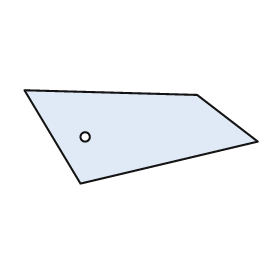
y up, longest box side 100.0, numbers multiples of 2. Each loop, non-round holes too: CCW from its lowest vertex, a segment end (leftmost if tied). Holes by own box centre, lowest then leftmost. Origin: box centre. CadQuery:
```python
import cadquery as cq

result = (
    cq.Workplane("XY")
    .moveTo(-26.0, -20.0)
    .lineTo(50.0, -2.0)
    .lineTo(24.0, 18.0)
    .lineTo(-50.0, 20.0)
    .close()
    .moveTo(-24.0, 0.0)
    .circle(2.0)
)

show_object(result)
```